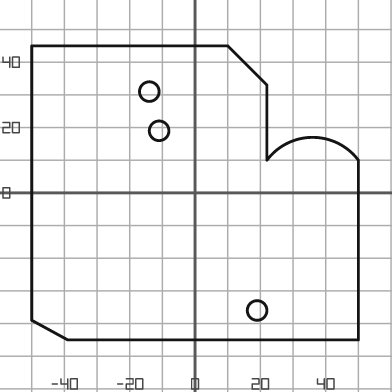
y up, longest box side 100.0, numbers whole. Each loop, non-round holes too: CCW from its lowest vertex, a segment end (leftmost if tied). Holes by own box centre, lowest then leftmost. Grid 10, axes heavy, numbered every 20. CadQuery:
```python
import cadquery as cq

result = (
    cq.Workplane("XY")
    .moveTo(-39.0, -45.0)
    .lineTo(50.0, -45.0)
    .lineTo(50.0, 10.0)
    .threePointArc((36.0, 17.0), (22.0, 10.0))
    .lineTo(22.0, 33.0)
    .lineTo(10.0, 45.0)
    .lineTo(-50.0, 45.0)
    .lineTo(-50.0, -39.0)
    .close()
    .moveTo(19.0, -36.0)
    .circle(3.0)
    .moveTo(-11.0, 19.0)
    .circle(3.0)
    .moveTo(-14.0, 31.0)
    .circle(3.0)
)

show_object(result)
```